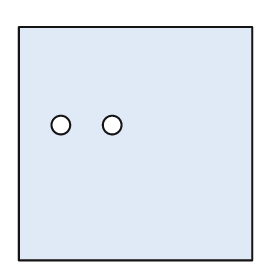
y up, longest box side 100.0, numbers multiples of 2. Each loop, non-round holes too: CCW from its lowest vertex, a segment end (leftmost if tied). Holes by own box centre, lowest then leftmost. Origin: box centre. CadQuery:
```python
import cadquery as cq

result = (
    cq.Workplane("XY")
    .moveTo(-50.0, -50.0)
    .lineTo(50.0, -50.0)
    .lineTo(50.0, 50.0)
    .lineTo(-50.0, 50.0)
    .close()
    .moveTo(-32.0, 8.0)
    .circle(4.0)
    .moveTo(-10.0, 8.0)
    .circle(4.0)
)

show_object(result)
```